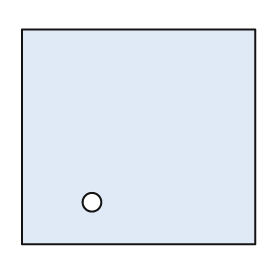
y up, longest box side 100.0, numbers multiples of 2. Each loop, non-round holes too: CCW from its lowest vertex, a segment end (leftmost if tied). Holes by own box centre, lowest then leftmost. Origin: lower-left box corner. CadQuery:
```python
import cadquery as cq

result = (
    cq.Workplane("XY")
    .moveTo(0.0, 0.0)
    .lineTo(100.0, 0.0)
    .lineTo(100.0, 92.0)
    .lineTo(0.0, 92.0)
    .close()
    .moveTo(30.0, 18.0)
    .circle(4.0)
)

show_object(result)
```